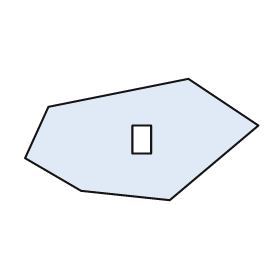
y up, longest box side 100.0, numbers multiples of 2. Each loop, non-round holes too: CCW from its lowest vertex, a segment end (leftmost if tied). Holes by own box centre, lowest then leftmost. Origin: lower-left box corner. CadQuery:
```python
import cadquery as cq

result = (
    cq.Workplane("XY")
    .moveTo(62.0, 0.0)
    .lineTo(100.0, 32.0)
    .lineTo(70.0, 52.0)
    .lineTo(10.0, 40.0)
    .lineTo(0.0, 18.0)
    .lineTo(24.0, 4.0)
    .close()
    .moveTo(46.0, 20.0)
    .lineTo(54.0, 20.0)
    .lineTo(54.0, 32.0)
    .lineTo(46.0, 32.0)
    .close()
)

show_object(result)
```